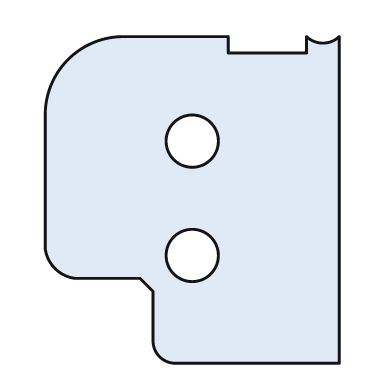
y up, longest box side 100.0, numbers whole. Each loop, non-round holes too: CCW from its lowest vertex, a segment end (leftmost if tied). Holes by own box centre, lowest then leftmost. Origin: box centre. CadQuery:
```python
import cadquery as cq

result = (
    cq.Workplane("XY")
    .moveTo(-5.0, -50.0)
    .lineTo(45.0, -50.0)
    .lineTo(45.0, 50.0)
    .threePointArc((40.0, 48.0), (35.0, 50.0))
    .lineTo(35.0, 45.0)
    .lineTo(11.0, 45.0)
    .lineTo(11.0, 50.0)
    .lineTo(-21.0, 50.0)
    .threePointArc((-38.0, 43.0), (-45.0, 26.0))
    .lineTo(-45.0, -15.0)
    .threePointArc((-42.0, -21.0), (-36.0, -24.0))
    .lineTo(-16.0, -24.0)
    .lineTo(-12.0, -28.0)
    .lineTo(-12.0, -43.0)
    .threePointArc((-10.0, -48.0), (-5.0, -50.0))
    .close()
    .moveTo(0.0, -17.0)
    .circle(8.0)
    .moveTo(0.0, 18.0)
    .circle(8.0)
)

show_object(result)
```